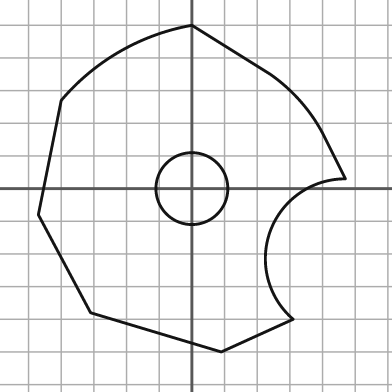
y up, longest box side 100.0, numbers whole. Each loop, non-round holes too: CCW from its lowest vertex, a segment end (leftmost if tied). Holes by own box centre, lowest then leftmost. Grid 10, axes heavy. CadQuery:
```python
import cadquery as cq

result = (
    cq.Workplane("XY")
    .moveTo(9.0, -50.0)
    .lineTo(31.0, -40.0)
    .threePointArc((24.0, -13.0), (47.0, 3.0))
    .lineTo(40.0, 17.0)
    .threePointArc((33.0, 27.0), (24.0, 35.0))
    .lineTo(0.0, 50.0)
    .threePointArc((-22.0, 42.0), (-40.0, 27.0))
    .lineTo(-47.0, -8.0)
    .lineTo(-31.0, -38.0)
    .close()
    .moveTo(0.0, 0.0)
    .circle(11.0)
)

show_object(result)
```